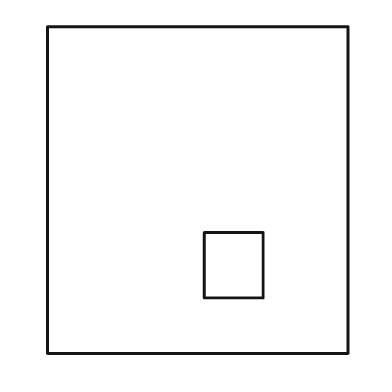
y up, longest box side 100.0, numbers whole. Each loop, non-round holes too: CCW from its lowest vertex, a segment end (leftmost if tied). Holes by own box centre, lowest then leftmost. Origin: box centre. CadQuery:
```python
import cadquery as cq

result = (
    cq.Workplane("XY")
    .moveTo(-46.0, -50.0)
    .lineTo(46.0, -50.0)
    .lineTo(46.0, 50.0)
    .lineTo(-46.0, 50.0)
    .close()
    .moveTo(2.0, -33.0)
    .lineTo(20.0, -33.0)
    .lineTo(20.0, -13.0)
    .lineTo(2.0, -13.0)
    .close()
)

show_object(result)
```